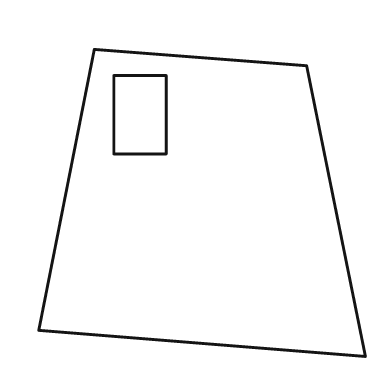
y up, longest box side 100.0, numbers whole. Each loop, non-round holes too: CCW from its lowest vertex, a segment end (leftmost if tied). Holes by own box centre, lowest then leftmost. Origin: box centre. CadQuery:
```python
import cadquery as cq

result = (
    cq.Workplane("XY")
    .moveTo(50.0, -47.0)
    .lineTo(32.0, 42.0)
    .lineTo(-33.0, 47.0)
    .lineTo(-50.0, -39.0)
    .close()
    .moveTo(-27.0, 15.0)
    .lineTo(-11.0, 15.0)
    .lineTo(-11.0, 39.0)
    .lineTo(-27.0, 39.0)
    .close()
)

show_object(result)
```